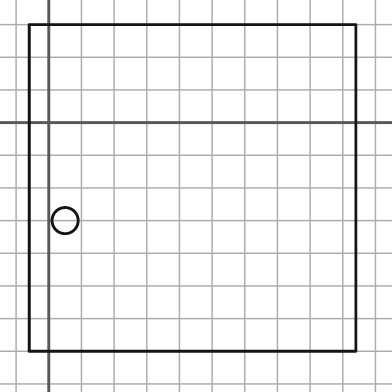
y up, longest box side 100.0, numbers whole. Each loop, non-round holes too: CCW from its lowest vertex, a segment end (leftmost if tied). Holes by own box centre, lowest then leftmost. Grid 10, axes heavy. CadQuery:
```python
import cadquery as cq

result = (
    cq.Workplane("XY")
    .moveTo(-6.0, -70.0)
    .lineTo(94.0, -70.0)
    .lineTo(94.0, 30.0)
    .lineTo(-6.0, 30.0)
    .close()
    .moveTo(5.0, -30.0)
    .circle(4.0)
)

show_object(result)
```